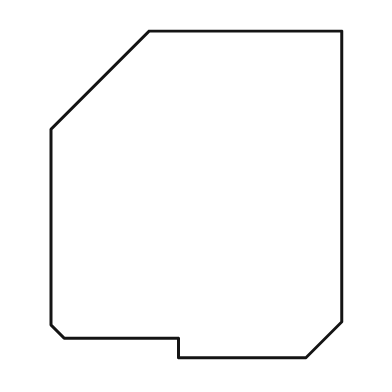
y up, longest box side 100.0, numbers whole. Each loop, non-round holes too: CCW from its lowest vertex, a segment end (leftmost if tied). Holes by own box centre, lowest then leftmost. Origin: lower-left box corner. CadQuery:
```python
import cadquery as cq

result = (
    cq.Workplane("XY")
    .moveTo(39.0, 0.0)
    .lineTo(78.0, 0.0)
    .lineTo(89.0, 11.0)
    .lineTo(89.0, 100.0)
    .lineTo(30.0, 100.0)
    .lineTo(0.0, 70.0)
    .lineTo(0.0, 10.0)
    .lineTo(4.0, 6.0)
    .lineTo(39.0, 6.0)
    .close()
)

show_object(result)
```